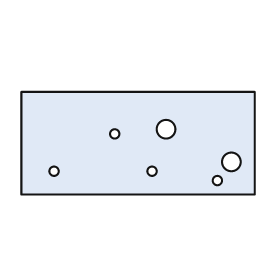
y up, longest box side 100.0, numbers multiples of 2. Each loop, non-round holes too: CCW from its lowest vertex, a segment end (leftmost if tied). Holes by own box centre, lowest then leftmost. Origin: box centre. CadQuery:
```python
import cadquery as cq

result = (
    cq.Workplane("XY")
    .moveTo(-50.0, -22.0)
    .lineTo(50.0, -22.0)
    .lineTo(50.0, 22.0)
    .lineTo(-50.0, 22.0)
    .close()
    .moveTo(34.0, -16.0)
    .circle(2.0)
    .moveTo(-36.0, -12.0)
    .circle(2.0)
    .moveTo(6.0, -12.0)
    .circle(2.0)
    .moveTo(40.0, -8.0)
    .circle(4.0)
    .moveTo(-10.0, 4.0)
    .circle(2.0)
    .moveTo(12.0, 6.0)
    .circle(4.0)
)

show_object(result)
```